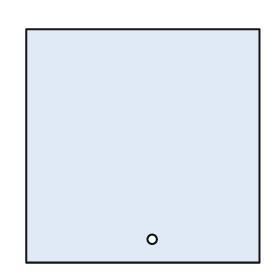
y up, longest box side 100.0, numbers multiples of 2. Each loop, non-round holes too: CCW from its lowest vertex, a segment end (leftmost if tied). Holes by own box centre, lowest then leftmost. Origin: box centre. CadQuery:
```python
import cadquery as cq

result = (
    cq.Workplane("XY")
    .moveTo(-50.0, -50.0)
    .lineTo(50.0, -50.0)
    .lineTo(50.0, 50.0)
    .lineTo(-50.0, 50.0)
    .close()
    .moveTo(4.0, -40.0)
    .circle(2.0)
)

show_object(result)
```